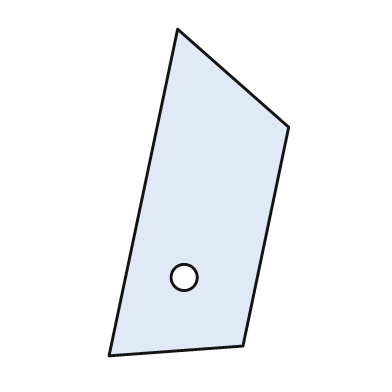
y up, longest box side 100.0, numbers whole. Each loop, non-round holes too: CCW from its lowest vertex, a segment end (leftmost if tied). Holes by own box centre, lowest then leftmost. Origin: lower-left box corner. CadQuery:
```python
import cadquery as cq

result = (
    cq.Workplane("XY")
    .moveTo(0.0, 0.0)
    .lineTo(41.0, 3.0)
    .lineTo(55.0, 70.0)
    .lineTo(21.0, 100.0)
    .close()
    .moveTo(23.0, 24.0)
    .circle(4.0)
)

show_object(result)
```